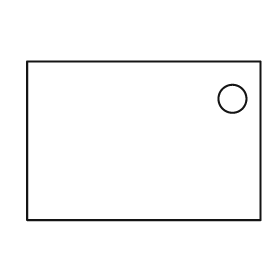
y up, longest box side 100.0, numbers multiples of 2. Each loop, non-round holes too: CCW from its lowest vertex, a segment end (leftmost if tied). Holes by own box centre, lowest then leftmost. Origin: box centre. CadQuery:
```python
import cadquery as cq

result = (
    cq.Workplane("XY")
    .moveTo(-50.0, -34.0)
    .lineTo(50.0, -34.0)
    .lineTo(50.0, 34.0)
    .lineTo(-50.0, 34.0)
    .close()
    .moveTo(38.0, 18.0)
    .circle(6.0)
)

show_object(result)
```